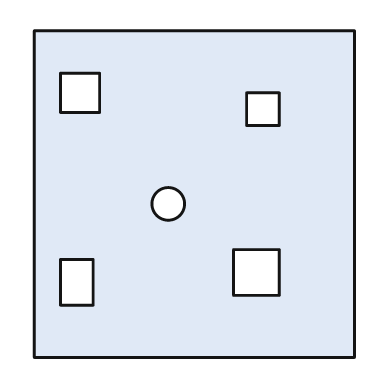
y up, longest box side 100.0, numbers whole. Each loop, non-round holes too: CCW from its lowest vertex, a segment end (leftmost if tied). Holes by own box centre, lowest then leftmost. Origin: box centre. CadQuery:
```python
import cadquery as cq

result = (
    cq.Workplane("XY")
    .moveTo(-49.0, -50.0)
    .lineTo(49.0, -50.0)
    .lineTo(49.0, 50.0)
    .lineTo(-49.0, 50.0)
    .close()
    .moveTo(-41.0, -34.0)
    .lineTo(-31.0, -34.0)
    .lineTo(-31.0, -20.0)
    .lineTo(-41.0, -20.0)
    .close()
    .moveTo(12.0, -31.0)
    .lineTo(26.0, -31.0)
    .lineTo(26.0, -17.0)
    .lineTo(12.0, -17.0)
    .close()
    .moveTo(-8.0, -3.0)
    .circle(5.0)
    .moveTo(16.0, 21.0)
    .lineTo(26.0, 21.0)
    .lineTo(26.0, 31.0)
    .lineTo(16.0, 31.0)
    .close()
    .moveTo(-41.0, 25.0)
    .lineTo(-29.0, 25.0)
    .lineTo(-29.0, 37.0)
    .lineTo(-41.0, 37.0)
    .close()
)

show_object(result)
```